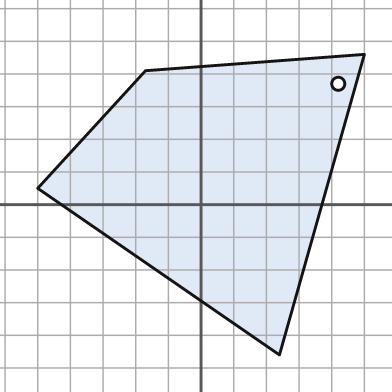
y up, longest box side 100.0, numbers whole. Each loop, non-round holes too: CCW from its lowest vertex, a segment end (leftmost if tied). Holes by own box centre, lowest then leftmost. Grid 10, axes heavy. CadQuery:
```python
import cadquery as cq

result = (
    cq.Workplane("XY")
    .moveTo(24.0, -46.0)
    .lineTo(50.0, 46.0)
    .lineTo(-17.0, 41.0)
    .lineTo(-50.0, 5.0)
    .close()
    .moveTo(42.0, 37.0)
    .circle(2.0)
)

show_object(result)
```